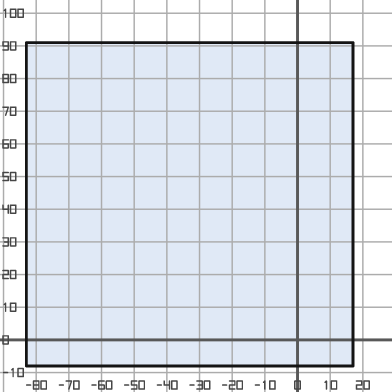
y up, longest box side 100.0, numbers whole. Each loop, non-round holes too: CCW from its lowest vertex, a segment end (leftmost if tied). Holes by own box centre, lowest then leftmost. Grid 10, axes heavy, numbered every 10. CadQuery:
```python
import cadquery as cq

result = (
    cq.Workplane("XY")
    .moveTo(-83.0, -8.0)
    .lineTo(17.0, -8.0)
    .lineTo(17.0, 91.0)
    .lineTo(-83.0, 91.0)
    .close()
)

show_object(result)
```